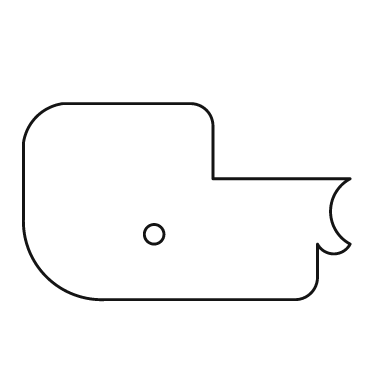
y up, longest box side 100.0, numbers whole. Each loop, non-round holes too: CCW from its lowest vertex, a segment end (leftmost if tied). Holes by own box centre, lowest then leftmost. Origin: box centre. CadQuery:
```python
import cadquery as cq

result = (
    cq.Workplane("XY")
    .moveTo(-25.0, -30.0)
    .lineTo(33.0, -30.0)
    .threePointArc((38.0, -28.0), (40.0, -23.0))
    .lineTo(40.0, -13.0)
    .threePointArc((45.0, -16.0), (50.0, -13.0))
    .threePointArc((44.0, -3.0), (50.0, 7.0))
    .lineTo(8.0, 7.0)
    .lineTo(8.0, 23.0)
    .threePointArc((6.0, 28.0), (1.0, 30.0))
    .lineTo(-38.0, 30.0)
    .threePointArc((-46.0, 26.0), (-50.0, 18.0))
    .lineTo(-50.0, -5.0)
    .threePointArc((-43.0, -23.0), (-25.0, -30.0))
    .close()
    .moveTo(-10.0, -10.0)
    .circle(3.0)
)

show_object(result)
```